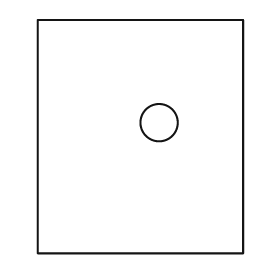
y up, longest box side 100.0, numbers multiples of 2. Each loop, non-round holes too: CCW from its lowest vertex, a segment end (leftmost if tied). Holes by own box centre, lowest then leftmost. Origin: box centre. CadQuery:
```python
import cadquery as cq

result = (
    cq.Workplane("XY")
    .moveTo(-44.0, -50.0)
    .lineTo(44.0, -50.0)
    .lineTo(44.0, 50.0)
    .lineTo(-44.0, 50.0)
    .close()
    .moveTo(8.0, 6.0)
    .circle(8.0)
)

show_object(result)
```